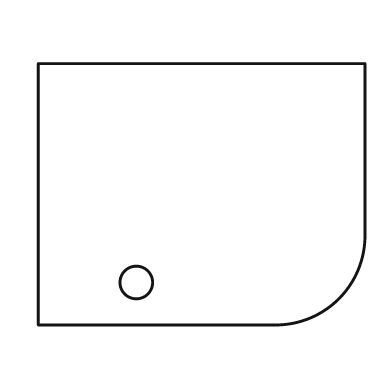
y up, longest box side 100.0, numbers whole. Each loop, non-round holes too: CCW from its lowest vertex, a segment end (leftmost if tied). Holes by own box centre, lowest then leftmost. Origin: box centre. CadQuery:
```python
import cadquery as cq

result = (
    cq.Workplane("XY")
    .moveTo(-50.0, -40.0)
    .lineTo(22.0, -40.0)
    .threePointArc((42.0, -32.0), (50.0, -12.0))
    .lineTo(50.0, 40.0)
    .lineTo(-50.0, 40.0)
    .close()
    .moveTo(-20.0, -27.0)
    .circle(5.0)
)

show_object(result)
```